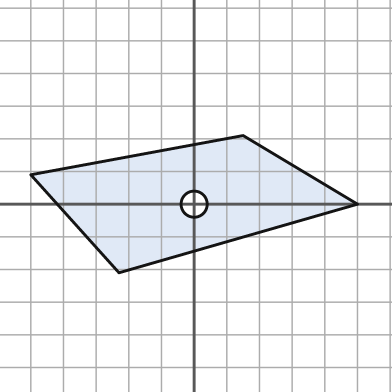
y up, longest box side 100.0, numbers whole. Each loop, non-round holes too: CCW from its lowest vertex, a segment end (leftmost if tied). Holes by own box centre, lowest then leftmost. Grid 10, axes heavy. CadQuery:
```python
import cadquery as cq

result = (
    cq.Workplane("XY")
    .moveTo(-23.0, -21.0)
    .lineTo(50.0, 0.0)
    .lineTo(15.0, 21.0)
    .lineTo(-50.0, 9.0)
    .close()
    .moveTo(0.0, 0.0)
    .circle(4.0)
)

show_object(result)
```